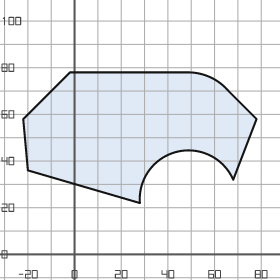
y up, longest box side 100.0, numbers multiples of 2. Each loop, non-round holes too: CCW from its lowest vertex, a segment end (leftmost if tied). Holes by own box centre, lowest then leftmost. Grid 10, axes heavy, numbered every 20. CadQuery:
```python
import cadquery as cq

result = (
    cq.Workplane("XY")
    .moveTo(28.0, 22.0)
    .threePointArc((44.0, 44.0), (68.0, 32.0))
    .lineTo(78.0, 58.0)
    .lineTo(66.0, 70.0)
    .threePointArc((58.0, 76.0), (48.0, 78.0))
    .lineTo(-2.0, 78.0)
    .lineTo(-22.0, 58.0)
    .lineTo(-20.0, 36.0)
    .close()
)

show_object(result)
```